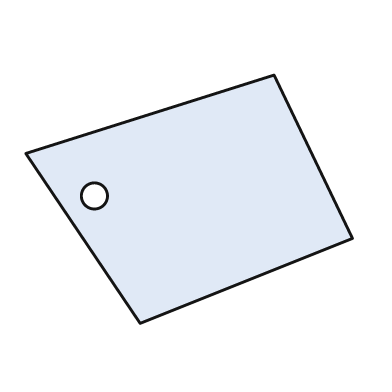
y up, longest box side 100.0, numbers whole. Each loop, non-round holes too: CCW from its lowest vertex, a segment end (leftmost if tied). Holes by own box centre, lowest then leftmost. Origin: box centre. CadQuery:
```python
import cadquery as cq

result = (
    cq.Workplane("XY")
    .moveTo(-15.0, -38.0)
    .lineTo(50.0, -12.0)
    .lineTo(26.0, 38.0)
    .lineTo(-50.0, 14.0)
    .close()
    .moveTo(-29.0, 1.0)
    .circle(4.0)
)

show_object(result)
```